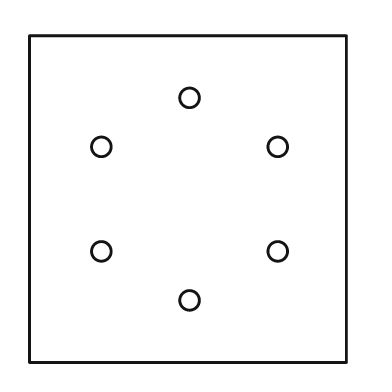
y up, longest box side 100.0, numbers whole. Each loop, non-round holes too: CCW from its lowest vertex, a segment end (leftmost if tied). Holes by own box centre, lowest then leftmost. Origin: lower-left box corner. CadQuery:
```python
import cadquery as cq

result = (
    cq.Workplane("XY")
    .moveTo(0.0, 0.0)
    .lineTo(97.0, 0.0)
    .lineTo(97.0, 100.0)
    .lineTo(0.0, 100.0)
    .close()
    .moveTo(49.0, 19.0)
    .circle(3.0)
    .moveTo(22.0, 34.0)
    .circle(3.0)
    .moveTo(76.0, 34.0)
    .circle(3.0)
    .moveTo(22.0, 66.0)
    .circle(3.0)
    .moveTo(76.0, 66.0)
    .circle(3.0)
    .moveTo(49.0, 81.0)
    .circle(3.0)
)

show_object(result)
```